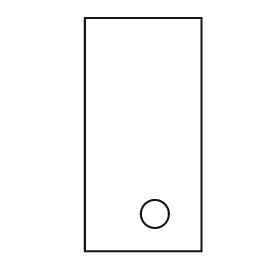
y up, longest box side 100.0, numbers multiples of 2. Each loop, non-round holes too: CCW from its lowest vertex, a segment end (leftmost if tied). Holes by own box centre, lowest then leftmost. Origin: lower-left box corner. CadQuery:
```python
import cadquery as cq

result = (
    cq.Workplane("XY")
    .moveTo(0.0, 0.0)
    .lineTo(50.0, 0.0)
    .lineTo(50.0, 100.0)
    .lineTo(0.0, 100.0)
    .close()
    .moveTo(30.0, 16.0)
    .circle(6.0)
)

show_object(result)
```